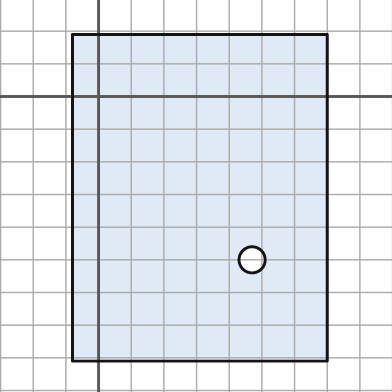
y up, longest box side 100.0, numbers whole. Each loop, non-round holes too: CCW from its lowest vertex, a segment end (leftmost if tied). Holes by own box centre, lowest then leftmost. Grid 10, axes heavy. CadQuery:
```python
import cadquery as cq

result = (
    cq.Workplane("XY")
    .moveTo(-8.0, -81.0)
    .lineTo(70.0, -81.0)
    .lineTo(70.0, 19.0)
    .lineTo(-8.0, 19.0)
    .close()
    .moveTo(47.0, -50.0)
    .circle(4.0)
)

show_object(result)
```